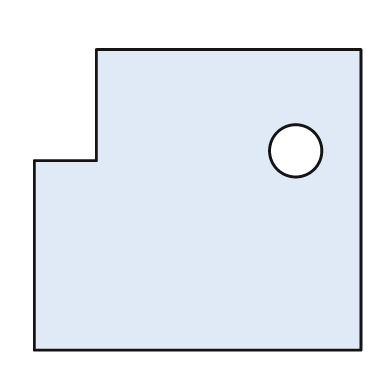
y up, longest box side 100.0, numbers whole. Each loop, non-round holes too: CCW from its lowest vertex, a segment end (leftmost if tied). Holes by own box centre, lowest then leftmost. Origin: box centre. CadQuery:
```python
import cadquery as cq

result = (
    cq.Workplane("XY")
    .moveTo(-50.0, -46.0)
    .lineTo(50.0, -46.0)
    .lineTo(50.0, 46.0)
    .lineTo(-31.0, 46.0)
    .lineTo(-31.0, 12.0)
    .lineTo(-50.0, 12.0)
    .close()
    .moveTo(30.0, 15.0)
    .circle(8.0)
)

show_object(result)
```